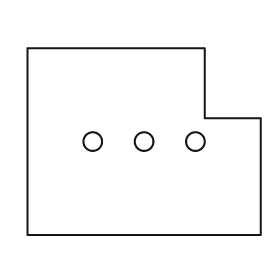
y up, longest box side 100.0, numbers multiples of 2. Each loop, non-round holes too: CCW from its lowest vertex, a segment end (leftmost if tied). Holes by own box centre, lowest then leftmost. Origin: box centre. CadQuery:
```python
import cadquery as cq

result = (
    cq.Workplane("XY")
    .moveTo(-50.0, -40.0)
    .lineTo(50.0, -40.0)
    .lineTo(50.0, 10.0)
    .lineTo(26.0, 10.0)
    .lineTo(26.0, 40.0)
    .lineTo(-50.0, 40.0)
    .close()
    .moveTo(-22.0, 0.0)
    .circle(4.0)
    .moveTo(0.0, 0.0)
    .circle(4.0)
    .moveTo(22.0, 0.0)
    .circle(4.0)
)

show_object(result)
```